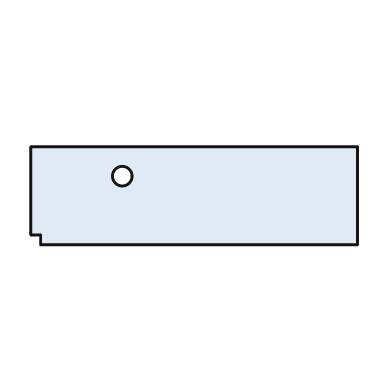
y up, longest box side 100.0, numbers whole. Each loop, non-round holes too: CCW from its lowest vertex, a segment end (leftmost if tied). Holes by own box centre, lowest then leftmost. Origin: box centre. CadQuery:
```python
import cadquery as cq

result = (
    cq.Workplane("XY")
    .moveTo(-47.0, -15.0)
    .lineTo(50.0, -15.0)
    .lineTo(50.0, 15.0)
    .lineTo(-50.0, 15.0)
    .lineTo(-50.0, -12.0)
    .lineTo(-47.0, -12.0)
    .close()
    .moveTo(-22.0, 6.0)
    .circle(3.0)
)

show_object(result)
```